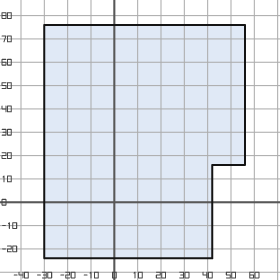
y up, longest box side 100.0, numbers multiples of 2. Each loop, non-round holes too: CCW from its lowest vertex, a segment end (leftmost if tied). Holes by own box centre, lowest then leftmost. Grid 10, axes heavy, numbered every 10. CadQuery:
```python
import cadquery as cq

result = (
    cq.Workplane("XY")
    .moveTo(-30.0, -24.0)
    .lineTo(42.0, -24.0)
    .lineTo(42.0, 16.0)
    .lineTo(56.0, 16.0)
    .lineTo(56.0, 76.0)
    .lineTo(-30.0, 76.0)
    .close()
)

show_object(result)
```